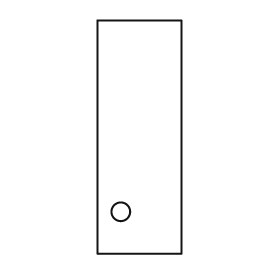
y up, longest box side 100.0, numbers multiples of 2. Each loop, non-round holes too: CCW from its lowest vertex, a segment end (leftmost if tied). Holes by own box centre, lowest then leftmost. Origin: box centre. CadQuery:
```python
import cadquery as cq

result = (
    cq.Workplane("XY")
    .moveTo(-18.0, -50.0)
    .lineTo(18.0, -50.0)
    .lineTo(18.0, 50.0)
    .lineTo(-18.0, 50.0)
    .close()
    .moveTo(-8.0, -32.0)
    .circle(4.0)
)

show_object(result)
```